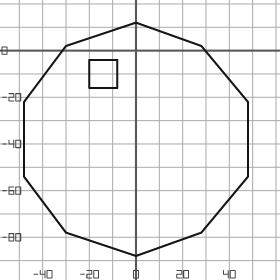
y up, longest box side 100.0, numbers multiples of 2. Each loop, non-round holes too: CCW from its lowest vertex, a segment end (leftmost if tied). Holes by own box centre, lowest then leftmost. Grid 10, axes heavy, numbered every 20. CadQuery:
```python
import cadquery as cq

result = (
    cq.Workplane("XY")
    .moveTo(0.0, -88.0)
    .lineTo(28.0, -78.0)
    .lineTo(48.0, -54.0)
    .lineTo(48.0, -22.0)
    .lineTo(28.0, 2.0)
    .lineTo(0.0, 12.0)
    .lineTo(-30.0, 2.0)
    .lineTo(-48.0, -22.0)
    .lineTo(-48.0, -54.0)
    .lineTo(-30.0, -78.0)
    .close()
    .moveTo(-20.0, -16.0)
    .lineTo(-8.0, -16.0)
    .lineTo(-8.0, -4.0)
    .lineTo(-20.0, -4.0)
    .close()
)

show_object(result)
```